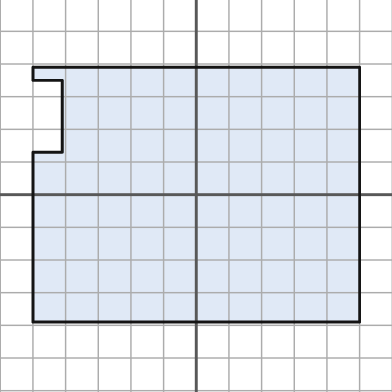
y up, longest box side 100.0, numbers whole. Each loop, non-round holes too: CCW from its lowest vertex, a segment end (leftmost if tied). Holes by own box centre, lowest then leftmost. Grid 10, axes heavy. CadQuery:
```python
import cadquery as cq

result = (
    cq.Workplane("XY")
    .moveTo(-50.0, -39.0)
    .lineTo(50.0, -39.0)
    .lineTo(50.0, 39.0)
    .lineTo(-50.0, 39.0)
    .lineTo(-50.0, 35.0)
    .lineTo(-41.0, 35.0)
    .lineTo(-41.0, 13.0)
    .lineTo(-50.0, 13.0)
    .close()
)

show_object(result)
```